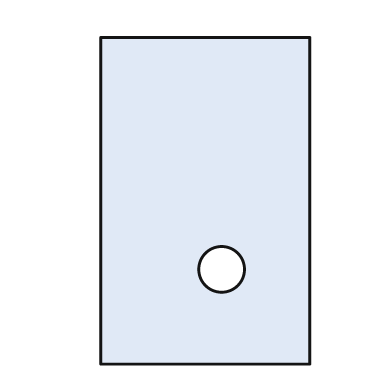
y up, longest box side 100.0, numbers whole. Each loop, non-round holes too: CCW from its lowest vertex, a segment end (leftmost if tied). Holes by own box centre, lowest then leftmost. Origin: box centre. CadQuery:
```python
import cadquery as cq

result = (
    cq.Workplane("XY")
    .moveTo(-32.0, -50.0)
    .lineTo(32.0, -50.0)
    .lineTo(32.0, 50.0)
    .lineTo(-32.0, 50.0)
    .close()
    .moveTo(5.0, -21.0)
    .circle(7.0)
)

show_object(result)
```